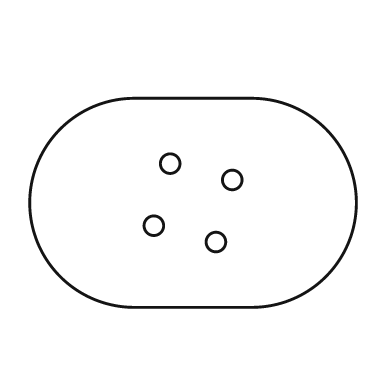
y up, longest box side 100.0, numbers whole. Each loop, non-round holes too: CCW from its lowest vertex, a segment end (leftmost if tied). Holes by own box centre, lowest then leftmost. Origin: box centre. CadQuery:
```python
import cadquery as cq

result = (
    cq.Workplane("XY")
    .moveTo(-18.0, -32.0)
    .lineTo(18.0, -32.0)
    .threePointArc((50.0, 0.0), (18.0, 32.0))
    .lineTo(-18.0, 32.0)
    .threePointArc((-50.0, 0.0), (-18.0, -32.0))
    .close()
    .moveTo(7.0, -12.0)
    .circle(3.0)
    .moveTo(-12.0, -7.0)
    .circle(3.0)
    .moveTo(12.0, 7.0)
    .circle(3.0)
    .moveTo(-7.0, 12.0)
    .circle(3.0)
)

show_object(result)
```